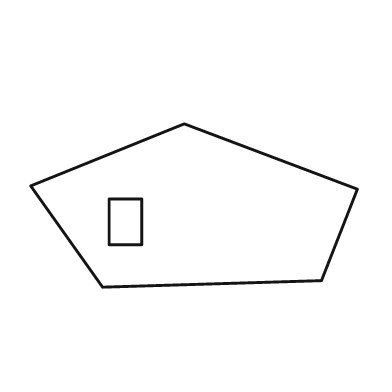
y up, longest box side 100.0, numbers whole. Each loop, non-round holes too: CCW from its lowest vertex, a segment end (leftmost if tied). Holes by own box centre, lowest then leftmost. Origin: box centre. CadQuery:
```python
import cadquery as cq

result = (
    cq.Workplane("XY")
    .moveTo(-28.0, -25.0)
    .lineTo(39.0, -23.0)
    .lineTo(50.0, 5.0)
    .lineTo(-3.0, 25.0)
    .lineTo(-50.0, 6.0)
    .close()
    .moveTo(-26.0, -12.0)
    .lineTo(-16.0, -12.0)
    .lineTo(-16.0, 2.0)
    .lineTo(-26.0, 2.0)
    .close()
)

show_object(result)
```